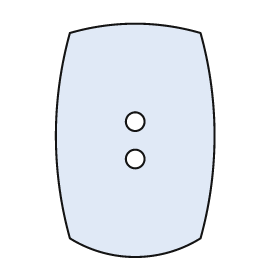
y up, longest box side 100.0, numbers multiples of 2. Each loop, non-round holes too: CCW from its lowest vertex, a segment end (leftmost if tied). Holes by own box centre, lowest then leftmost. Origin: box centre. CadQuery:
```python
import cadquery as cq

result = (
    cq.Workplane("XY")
    .moveTo(-28.0, -42.0)
    .threePointArc((0.0, -50.0), (28.0, -42.0))
    .threePointArc((34.0, 2.0), (28.0, 46.0))
    .threePointArc((0.0, 50.0), (-28.0, 46.0))
    .threePointArc((-34.0, 2.0), (-28.0, -42.0))
    .close()
    .moveTo(0.0, -8.0)
    .circle(4.0)
    .moveTo(0.0, 8.0)
    .circle(4.0)
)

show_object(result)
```